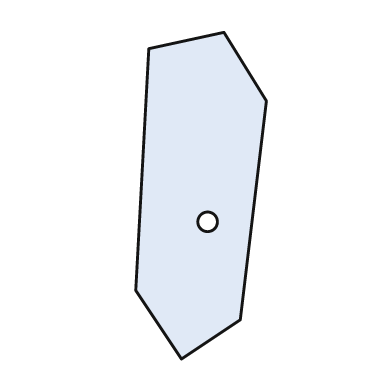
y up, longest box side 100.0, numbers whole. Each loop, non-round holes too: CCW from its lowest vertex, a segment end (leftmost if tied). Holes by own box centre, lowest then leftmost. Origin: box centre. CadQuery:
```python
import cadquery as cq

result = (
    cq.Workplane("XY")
    .moveTo(-6.0, -50.0)
    .lineTo(12.0, -38.0)
    .lineTo(20.0, 29.0)
    .lineTo(7.0, 50.0)
    .lineTo(-16.0, 45.0)
    .lineTo(-20.0, -29.0)
    .close()
    .moveTo(2.0, -8.0)
    .circle(3.0)
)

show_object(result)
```